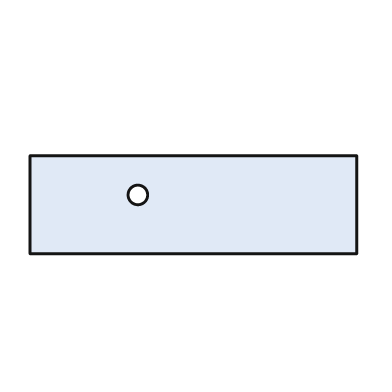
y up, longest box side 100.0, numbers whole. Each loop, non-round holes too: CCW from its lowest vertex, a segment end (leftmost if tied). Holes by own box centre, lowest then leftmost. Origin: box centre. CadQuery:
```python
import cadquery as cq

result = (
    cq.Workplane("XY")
    .moveTo(-50.0, -15.0)
    .lineTo(50.0, -15.0)
    .lineTo(50.0, 15.0)
    .lineTo(-50.0, 15.0)
    .close()
    .moveTo(-17.0, 3.0)
    .circle(3.0)
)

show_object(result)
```